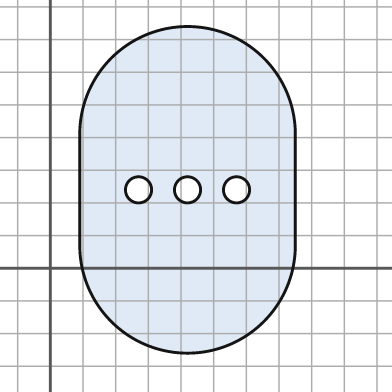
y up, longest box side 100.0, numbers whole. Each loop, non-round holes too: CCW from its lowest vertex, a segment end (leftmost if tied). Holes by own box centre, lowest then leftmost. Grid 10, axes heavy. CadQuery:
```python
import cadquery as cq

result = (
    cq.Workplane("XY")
    .moveTo(9.0, 7.0)
    .threePointArc((42.0, -26.0), (75.0, 7.0))
    .lineTo(75.0, 41.0)
    .threePointArc((42.0, 74.0), (9.0, 41.0))
    .close()
    .moveTo(27.0, 24.0)
    .circle(4.0)
    .moveTo(42.0, 24.0)
    .circle(4.0)
    .moveTo(57.0, 24.0)
    .circle(4.0)
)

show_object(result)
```